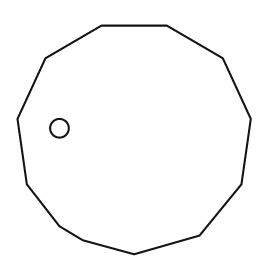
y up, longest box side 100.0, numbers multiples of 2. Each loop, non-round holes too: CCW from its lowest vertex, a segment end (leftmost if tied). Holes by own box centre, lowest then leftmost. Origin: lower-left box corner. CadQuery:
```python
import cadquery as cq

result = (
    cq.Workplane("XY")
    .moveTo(50.0, 0.0)
    .lineTo(78.0, 8.0)
    .lineTo(96.0, 30.0)
    .lineTo(100.0, 58.0)
    .lineTo(88.0, 84.0)
    .lineTo(64.0, 98.0)
    .lineTo(36.0, 98.0)
    .lineTo(12.0, 84.0)
    .lineTo(0.0, 58.0)
    .lineTo(4.0, 30.0)
    .lineTo(18.0, 12.0)
    .lineTo(28.0, 6.0)
    .close()
    .moveTo(18.0, 54.0)
    .circle(4.0)
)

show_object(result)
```